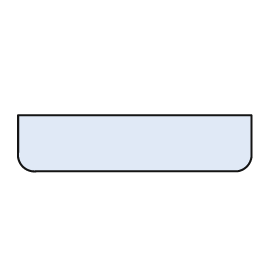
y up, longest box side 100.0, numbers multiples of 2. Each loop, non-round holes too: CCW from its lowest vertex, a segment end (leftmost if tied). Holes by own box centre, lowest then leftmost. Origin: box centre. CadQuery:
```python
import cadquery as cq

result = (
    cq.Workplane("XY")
    .moveTo(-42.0, -12.0)
    .lineTo(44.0, -12.0)
    .threePointArc((48.0, -10.0), (50.0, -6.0))
    .lineTo(50.0, 12.0)
    .lineTo(-50.0, 12.0)
    .lineTo(-50.0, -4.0)
    .threePointArc((-48.0, -10.0), (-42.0, -12.0))
    .close()
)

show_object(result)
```